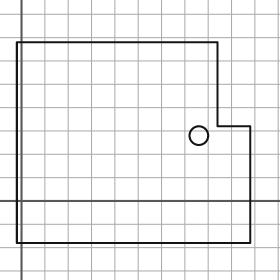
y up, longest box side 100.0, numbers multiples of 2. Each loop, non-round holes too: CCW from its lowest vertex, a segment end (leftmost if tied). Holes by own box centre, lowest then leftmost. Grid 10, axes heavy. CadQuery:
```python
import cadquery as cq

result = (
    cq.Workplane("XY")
    .moveTo(-2.0, -18.0)
    .lineTo(98.0, -18.0)
    .lineTo(98.0, 32.0)
    .lineTo(84.0, 32.0)
    .lineTo(84.0, 68.0)
    .lineTo(-2.0, 68.0)
    .close()
    .moveTo(76.0, 28.0)
    .circle(4.0)
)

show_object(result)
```